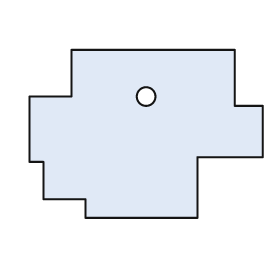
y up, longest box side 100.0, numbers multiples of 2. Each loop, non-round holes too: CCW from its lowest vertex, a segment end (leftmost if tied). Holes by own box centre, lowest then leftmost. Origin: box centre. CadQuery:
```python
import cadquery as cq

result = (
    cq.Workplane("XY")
    .moveTo(-26.0, -36.0)
    .lineTo(22.0, -36.0)
    .lineTo(22.0, -10.0)
    .lineTo(50.0, -10.0)
    .lineTo(50.0, 12.0)
    .lineTo(38.0, 12.0)
    .lineTo(38.0, 36.0)
    .lineTo(-32.0, 36.0)
    .lineTo(-32.0, 16.0)
    .lineTo(-50.0, 16.0)
    .lineTo(-50.0, -12.0)
    .lineTo(-44.0, -12.0)
    .lineTo(-44.0, -28.0)
    .lineTo(-26.0, -28.0)
    .close()
    .moveTo(0.0, 16.0)
    .circle(4.0)
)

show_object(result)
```